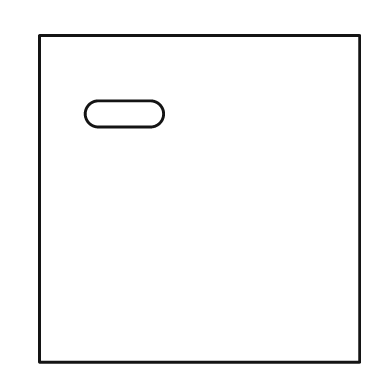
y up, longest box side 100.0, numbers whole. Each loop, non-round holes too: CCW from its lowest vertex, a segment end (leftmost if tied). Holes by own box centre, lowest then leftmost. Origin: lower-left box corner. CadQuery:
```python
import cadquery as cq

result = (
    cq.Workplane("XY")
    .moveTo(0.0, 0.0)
    .lineTo(98.0, 0.0)
    .lineTo(98.0, 100.0)
    .lineTo(0.0, 100.0)
    .close()
    .moveTo(18.0, 72.0)
    .lineTo(34.0, 72.0)
    .threePointArc((38.0, 76.0), (34.0, 80.0))
    .lineTo(18.0, 80.0)
    .threePointArc((14.0, 76.0), (18.0, 72.0))
    .close()
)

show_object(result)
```